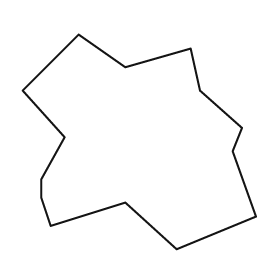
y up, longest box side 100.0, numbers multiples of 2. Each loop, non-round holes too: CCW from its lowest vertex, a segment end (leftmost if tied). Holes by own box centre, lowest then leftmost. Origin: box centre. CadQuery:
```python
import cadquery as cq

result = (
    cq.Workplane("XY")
    .moveTo(16.0, -46.0)
    .lineTo(50.0, -32.0)
    .lineTo(40.0, -4.0)
    .lineTo(44.0, 6.0)
    .lineTo(26.0, 22.0)
    .lineTo(22.0, 40.0)
    .lineTo(-6.0, 32.0)
    .lineTo(-26.0, 46.0)
    .lineTo(-50.0, 22.0)
    .lineTo(-32.0, 2.0)
    .lineTo(-42.0, -16.0)
    .lineTo(-42.0, -24.0)
    .lineTo(-38.0, -36.0)
    .lineTo(-6.0, -26.0)
    .close()
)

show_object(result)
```